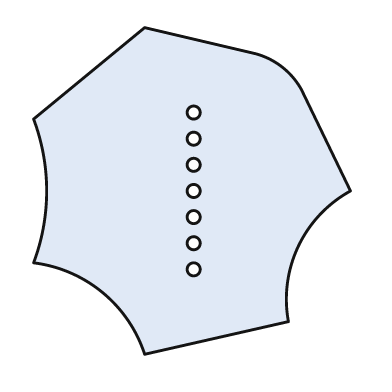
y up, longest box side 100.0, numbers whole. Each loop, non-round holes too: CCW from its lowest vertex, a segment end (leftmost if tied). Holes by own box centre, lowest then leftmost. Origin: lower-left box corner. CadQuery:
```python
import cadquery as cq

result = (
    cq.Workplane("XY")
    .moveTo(34.0, 0.0)
    .lineTo(78.0, 10.0)
    .threePointArc((81.0, 33.0), (97.0, 50.0))
    .lineTo(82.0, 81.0)
    .threePointArc((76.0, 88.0), (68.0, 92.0))
    .lineTo(34.0, 100.0)
    .lineTo(0.0, 72.0)
    .threePointArc((4.0, 50.0), (0.0, 28.0))
    .threePointArc((21.0, 19.0), (34.0, 0.0))
    .close()
    .moveTo(49.0, 26.0)
    .circle(2.0)
    .moveTo(49.0, 34.0)
    .circle(2.0)
    .moveTo(49.0, 42.0)
    .circle(2.0)
    .moveTo(49.0, 50.0)
    .circle(2.0)
    .moveTo(49.0, 58.0)
    .circle(2.0)
    .moveTo(49.0, 66.0)
    .circle(2.0)
    .moveTo(49.0, 74.0)
    .circle(2.0)
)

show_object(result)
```